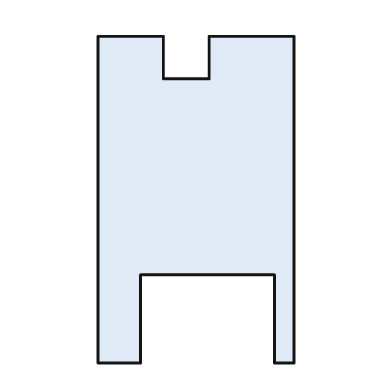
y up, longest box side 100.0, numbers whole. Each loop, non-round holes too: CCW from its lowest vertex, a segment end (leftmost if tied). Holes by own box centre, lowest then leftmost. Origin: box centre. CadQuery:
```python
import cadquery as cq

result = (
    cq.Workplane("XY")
    .moveTo(-30.0, -50.0)
    .lineTo(-17.0, -50.0)
    .lineTo(-17.0, -23.0)
    .lineTo(24.0, -23.0)
    .lineTo(24.0, -50.0)
    .lineTo(30.0, -50.0)
    .lineTo(30.0, 50.0)
    .lineTo(4.0, 50.0)
    .lineTo(4.0, 37.0)
    .lineTo(-10.0, 37.0)
    .lineTo(-10.0, 50.0)
    .lineTo(-30.0, 50.0)
    .close()
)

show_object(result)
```